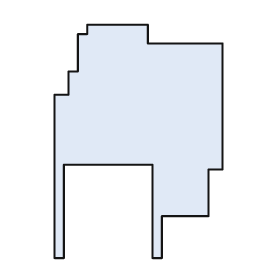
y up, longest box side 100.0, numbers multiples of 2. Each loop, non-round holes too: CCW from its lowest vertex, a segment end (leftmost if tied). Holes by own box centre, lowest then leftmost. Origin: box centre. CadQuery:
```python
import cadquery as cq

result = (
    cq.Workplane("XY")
    .moveTo(-36.0, -50.0)
    .lineTo(-32.0, -50.0)
    .lineTo(-32.0, -10.0)
    .lineTo(6.0, -10.0)
    .lineTo(6.0, -50.0)
    .lineTo(10.0, -50.0)
    .lineTo(10.0, -32.0)
    .lineTo(30.0, -32.0)
    .lineTo(30.0, -12.0)
    .lineTo(36.0, -12.0)
    .lineTo(36.0, 42.0)
    .lineTo(4.0, 42.0)
    .lineTo(4.0, 50.0)
    .lineTo(-22.0, 50.0)
    .lineTo(-22.0, 46.0)
    .lineTo(-26.0, 46.0)
    .lineTo(-26.0, 30.0)
    .lineTo(-30.0, 30.0)
    .lineTo(-30.0, 20.0)
    .lineTo(-36.0, 20.0)
    .close()
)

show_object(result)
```